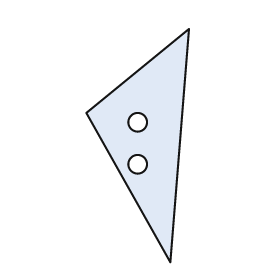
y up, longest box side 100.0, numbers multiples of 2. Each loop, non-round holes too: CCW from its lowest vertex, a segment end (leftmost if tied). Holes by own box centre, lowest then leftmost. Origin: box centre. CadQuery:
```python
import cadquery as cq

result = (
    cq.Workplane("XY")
    .moveTo(14.0, -50.0)
    .lineTo(22.0, 50.0)
    .lineTo(-22.0, 14.0)
    .close()
    .moveTo(0.0, -8.0)
    .circle(4.0)
    .moveTo(0.0, 10.0)
    .circle(4.0)
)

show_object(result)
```